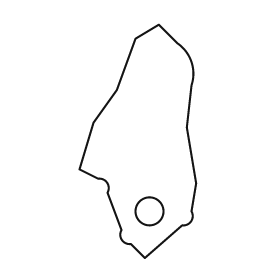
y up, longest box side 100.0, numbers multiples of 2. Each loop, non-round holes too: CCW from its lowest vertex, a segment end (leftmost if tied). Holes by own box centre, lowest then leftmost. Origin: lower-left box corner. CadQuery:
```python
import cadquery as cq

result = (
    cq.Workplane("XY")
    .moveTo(28.0, 0.0)
    .lineTo(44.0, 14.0)
    .threePointArc((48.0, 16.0), (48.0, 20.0))
    .lineTo(50.0, 32.0)
    .lineTo(46.0, 56.0)
    .lineTo(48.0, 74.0)
    .threePointArc((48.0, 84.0), (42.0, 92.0))
    .lineTo(34.0, 100.0)
    .lineTo(24.0, 94.0)
    .lineTo(16.0, 72.0)
    .lineTo(6.0, 58.0)
    .lineTo(0.0, 38.0)
    .lineTo(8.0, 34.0)
    .threePointArc((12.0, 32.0), (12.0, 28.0))
    .lineTo(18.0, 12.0)
    .threePointArc((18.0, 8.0), (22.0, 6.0))
    .close()
    .moveTo(30.0, 20.0)
    .circle(6.0)
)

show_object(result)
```